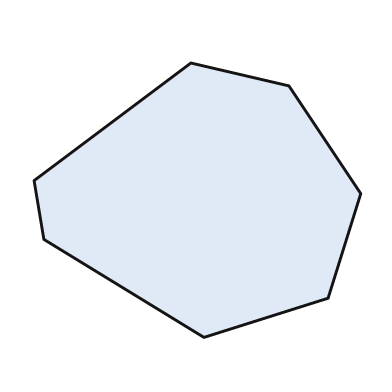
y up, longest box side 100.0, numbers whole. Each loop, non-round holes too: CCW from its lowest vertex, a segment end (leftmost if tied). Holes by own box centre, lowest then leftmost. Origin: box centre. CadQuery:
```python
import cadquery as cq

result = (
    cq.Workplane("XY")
    .moveTo(2.0, -42.0)
    .lineTo(40.0, -30.0)
    .lineTo(50.0, 2.0)
    .lineTo(28.0, 35.0)
    .lineTo(-2.0, 42.0)
    .lineTo(-50.0, 6.0)
    .lineTo(-47.0, -12.0)
    .close()
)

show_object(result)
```